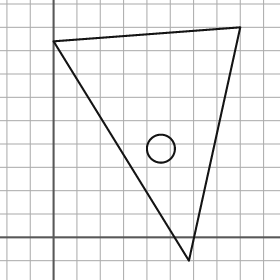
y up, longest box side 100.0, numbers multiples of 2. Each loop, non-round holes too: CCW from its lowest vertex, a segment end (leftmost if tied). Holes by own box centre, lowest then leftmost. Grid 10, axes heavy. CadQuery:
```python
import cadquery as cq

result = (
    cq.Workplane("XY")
    .moveTo(58.0, -10.0)
    .lineTo(80.0, 90.0)
    .lineTo(0.0, 84.0)
    .close()
    .moveTo(46.0, 38.0)
    .circle(6.0)
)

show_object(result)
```